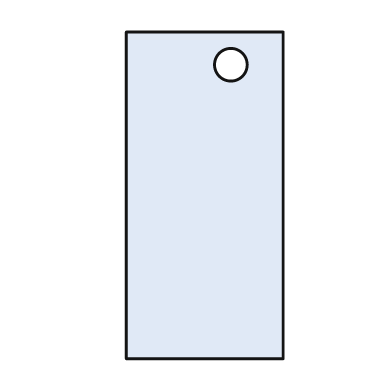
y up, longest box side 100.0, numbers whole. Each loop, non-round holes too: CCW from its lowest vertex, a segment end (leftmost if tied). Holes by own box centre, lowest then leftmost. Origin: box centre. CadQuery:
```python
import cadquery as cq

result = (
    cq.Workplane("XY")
    .moveTo(-24.0, -50.0)
    .lineTo(24.0, -50.0)
    .lineTo(24.0, 50.0)
    .lineTo(-24.0, 50.0)
    .close()
    .moveTo(8.0, 40.0)
    .circle(5.0)
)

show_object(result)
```